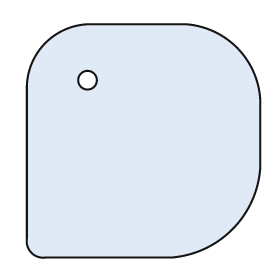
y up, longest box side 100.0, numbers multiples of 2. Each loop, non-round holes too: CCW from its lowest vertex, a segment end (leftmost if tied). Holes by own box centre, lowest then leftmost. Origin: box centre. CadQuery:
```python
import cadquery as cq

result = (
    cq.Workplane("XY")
    .moveTo(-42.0, -50.0)
    .lineTo(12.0, -50.0)
    .threePointArc((38.0, -38.0), (50.0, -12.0))
    .lineTo(50.0, 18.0)
    .threePointArc((40.0, 40.0), (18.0, 50.0))
    .lineTo(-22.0, 50.0)
    .threePointArc((-42.0, 42.0), (-50.0, 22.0))
    .lineTo(-50.0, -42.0)
    .threePointArc((-48.0, -48.0), (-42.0, -50.0))
    .close()
    .moveTo(-24.0, 26.0)
    .circle(4.0)
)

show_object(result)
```